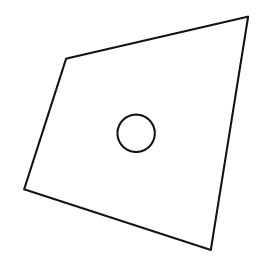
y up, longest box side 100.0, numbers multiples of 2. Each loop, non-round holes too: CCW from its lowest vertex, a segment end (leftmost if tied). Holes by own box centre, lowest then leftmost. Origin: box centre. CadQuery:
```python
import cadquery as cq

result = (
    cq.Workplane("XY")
    .moveTo(32.0, -50.0)
    .lineTo(48.0, 50.0)
    .lineTo(-30.0, 32.0)
    .lineTo(-48.0, -24.0)
    .close()
    .moveTo(0.0, 0.0)
    .circle(8.0)
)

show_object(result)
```